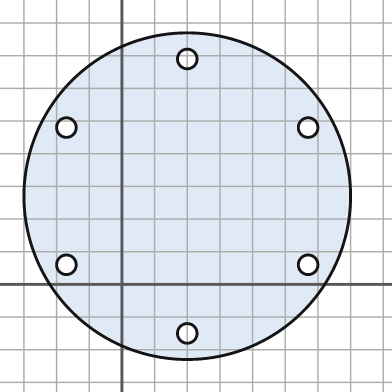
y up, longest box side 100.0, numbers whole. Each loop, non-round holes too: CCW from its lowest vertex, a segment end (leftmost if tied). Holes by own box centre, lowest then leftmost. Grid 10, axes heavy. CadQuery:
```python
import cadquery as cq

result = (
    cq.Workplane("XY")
    .moveTo(20.0, 27.0)
    .circle(50.0)
    .moveTo(20.0, -15.0)
    .circle(3.0)
    .moveTo(-17.0, 6.0)
    .circle(3.0)
    .moveTo(57.0, 6.0)
    .circle(3.0)
    .moveTo(-17.0, 48.0)
    .circle(3.0)
    .moveTo(57.0, 48.0)
    .circle(3.0)
    .moveTo(20.0, 69.0)
    .circle(3.0)
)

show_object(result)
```